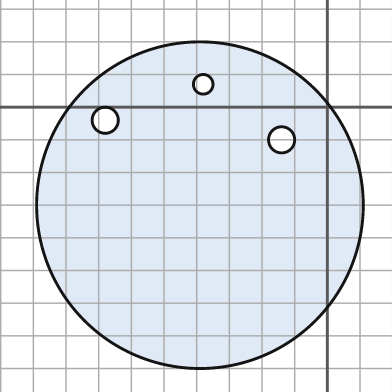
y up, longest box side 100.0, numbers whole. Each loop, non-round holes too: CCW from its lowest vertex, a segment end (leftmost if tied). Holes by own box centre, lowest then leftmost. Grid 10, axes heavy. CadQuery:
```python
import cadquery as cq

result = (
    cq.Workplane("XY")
    .moveTo(-39.0, -30.0)
    .circle(50.0)
    .moveTo(-14.0, -10.0)
    .circle(4.0)
    .moveTo(-68.0, -4.0)
    .circle(4.0)
    .moveTo(-38.0, 7.0)
    .circle(3.0)
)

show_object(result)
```